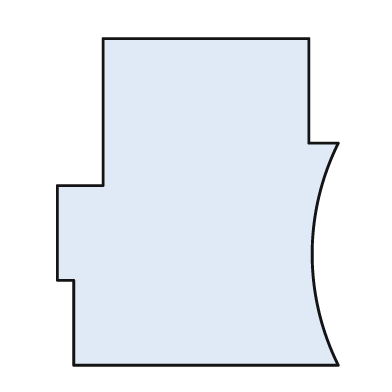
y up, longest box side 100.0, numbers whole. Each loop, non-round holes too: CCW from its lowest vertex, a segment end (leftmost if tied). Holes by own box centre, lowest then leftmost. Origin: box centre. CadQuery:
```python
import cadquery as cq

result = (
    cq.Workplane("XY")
    .moveTo(-38.0, -50.0)
    .lineTo(43.0, -50.0)
    .threePointArc((35.0, -16.0), (43.0, 18.0))
    .lineTo(34.0, 18.0)
    .lineTo(34.0, 50.0)
    .lineTo(-29.0, 50.0)
    .lineTo(-29.0, 5.0)
    .lineTo(-43.0, 5.0)
    .lineTo(-43.0, -24.0)
    .lineTo(-38.0, -24.0)
    .close()
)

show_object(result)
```